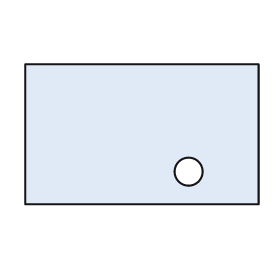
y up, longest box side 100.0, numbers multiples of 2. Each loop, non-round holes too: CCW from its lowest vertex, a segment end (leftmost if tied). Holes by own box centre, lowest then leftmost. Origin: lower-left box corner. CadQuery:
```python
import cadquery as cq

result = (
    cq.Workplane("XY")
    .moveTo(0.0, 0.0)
    .lineTo(100.0, 0.0)
    .lineTo(100.0, 60.0)
    .lineTo(0.0, 60.0)
    .close()
    .moveTo(70.0, 14.0)
    .circle(6.0)
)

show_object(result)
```